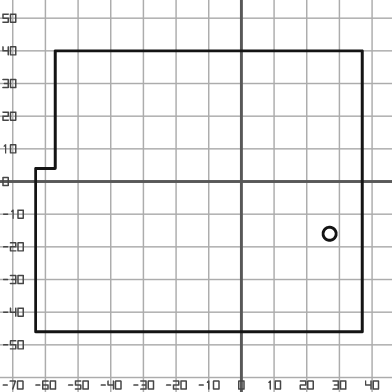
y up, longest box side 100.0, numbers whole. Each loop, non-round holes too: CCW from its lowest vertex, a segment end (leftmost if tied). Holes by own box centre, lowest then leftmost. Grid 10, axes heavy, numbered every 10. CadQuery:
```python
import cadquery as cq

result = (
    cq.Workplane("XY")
    .moveTo(-63.0, -46.0)
    .lineTo(37.0, -46.0)
    .lineTo(37.0, 40.0)
    .lineTo(-57.0, 40.0)
    .lineTo(-57.0, 4.0)
    .lineTo(-63.0, 4.0)
    .close()
    .moveTo(27.0, -16.0)
    .circle(2.0)
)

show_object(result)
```